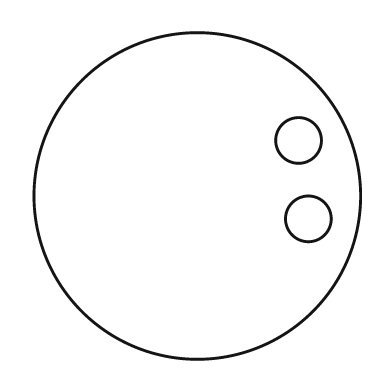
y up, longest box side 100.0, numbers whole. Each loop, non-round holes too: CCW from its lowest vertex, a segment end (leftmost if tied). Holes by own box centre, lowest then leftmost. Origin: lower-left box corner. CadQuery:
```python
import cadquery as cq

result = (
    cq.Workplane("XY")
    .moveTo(50.0, 50.0)
    .circle(50.0)
    .moveTo(84.0, 43.0)
    .circle(7.0)
    .moveTo(81.0, 67.0)
    .circle(7.0)
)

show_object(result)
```